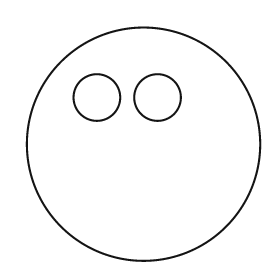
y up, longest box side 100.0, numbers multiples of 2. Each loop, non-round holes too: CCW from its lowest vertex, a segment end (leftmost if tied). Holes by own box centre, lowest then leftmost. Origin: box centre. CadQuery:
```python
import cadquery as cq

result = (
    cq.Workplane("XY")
    .moveTo(0.0, 0.0)
    .circle(50.0)
    .moveTo(-20.0, 20.0)
    .circle(10.0)
    .moveTo(6.0, 20.0)
    .circle(10.0)
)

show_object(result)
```